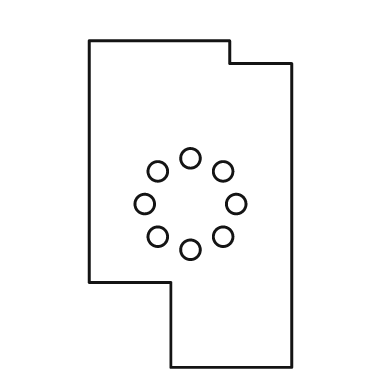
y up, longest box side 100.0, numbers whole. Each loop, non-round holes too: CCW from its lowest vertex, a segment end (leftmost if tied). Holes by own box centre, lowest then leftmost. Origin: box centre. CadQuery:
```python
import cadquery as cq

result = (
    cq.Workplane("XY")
    .moveTo(-6.0, -50.0)
    .lineTo(31.0, -50.0)
    .lineTo(31.0, 43.0)
    .lineTo(12.0, 43.0)
    .lineTo(12.0, 50.0)
    .lineTo(-31.0, 50.0)
    .lineTo(-31.0, -24.0)
    .lineTo(-6.0, -24.0)
    .close()
    .moveTo(0.0, -14.0)
    .circle(3.0)
    .moveTo(-10.0, -10.0)
    .circle(3.0)
    .moveTo(10.0, -10.0)
    .circle(3.0)
    .moveTo(-14.0, 0.0)
    .circle(3.0)
    .moveTo(14.0, 0.0)
    .circle(3.0)
    .moveTo(-10.0, 10.0)
    .circle(3.0)
    .moveTo(10.0, 10.0)
    .circle(3.0)
    .moveTo(0.0, 14.0)
    .circle(3.0)
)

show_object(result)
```